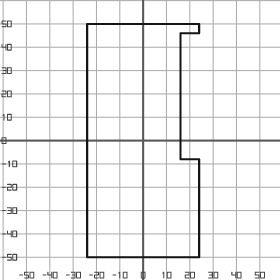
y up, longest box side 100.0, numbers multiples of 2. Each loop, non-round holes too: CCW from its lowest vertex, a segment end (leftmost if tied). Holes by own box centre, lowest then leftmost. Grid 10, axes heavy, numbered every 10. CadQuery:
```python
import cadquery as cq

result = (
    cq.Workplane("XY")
    .moveTo(-24.0, -50.0)
    .lineTo(24.0, -50.0)
    .lineTo(24.0, -8.0)
    .lineTo(16.0, -8.0)
    .lineTo(16.0, 46.0)
    .lineTo(24.0, 46.0)
    .lineTo(24.0, 50.0)
    .lineTo(-24.0, 50.0)
    .close()
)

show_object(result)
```